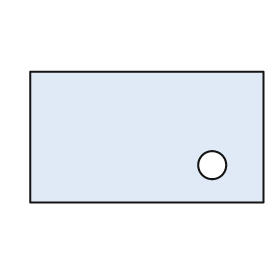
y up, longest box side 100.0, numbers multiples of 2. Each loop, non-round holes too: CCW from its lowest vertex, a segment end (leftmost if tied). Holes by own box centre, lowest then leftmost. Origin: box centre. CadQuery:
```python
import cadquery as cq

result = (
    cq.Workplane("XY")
    .moveTo(-50.0, -28.0)
    .lineTo(50.0, -28.0)
    .lineTo(50.0, 28.0)
    .lineTo(-50.0, 28.0)
    .close()
    .moveTo(28.0, -12.0)
    .circle(6.0)
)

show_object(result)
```